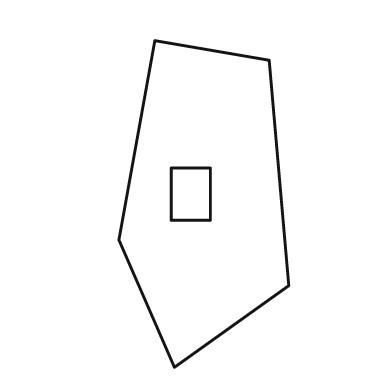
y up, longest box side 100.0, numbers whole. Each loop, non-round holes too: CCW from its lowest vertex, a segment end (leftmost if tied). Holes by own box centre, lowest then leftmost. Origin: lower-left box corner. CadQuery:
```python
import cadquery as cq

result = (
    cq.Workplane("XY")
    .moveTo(17.0, 0.0)
    .lineTo(52.0, 25.0)
    .lineTo(46.0, 94.0)
    .lineTo(11.0, 100.0)
    .lineTo(0.0, 39.0)
    .close()
    .moveTo(16.0, 45.0)
    .lineTo(28.0, 45.0)
    .lineTo(28.0, 61.0)
    .lineTo(16.0, 61.0)
    .close()
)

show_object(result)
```